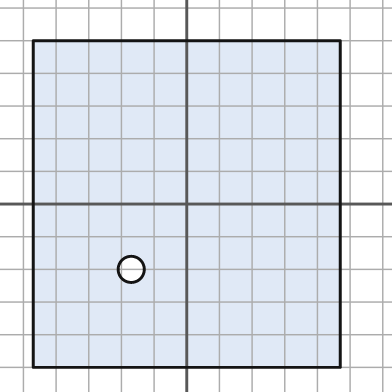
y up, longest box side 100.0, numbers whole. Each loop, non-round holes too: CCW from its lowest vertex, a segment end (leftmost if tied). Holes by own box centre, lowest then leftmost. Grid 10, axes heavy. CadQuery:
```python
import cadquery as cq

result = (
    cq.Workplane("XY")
    .moveTo(-47.0, -50.0)
    .lineTo(47.0, -50.0)
    .lineTo(47.0, 50.0)
    .lineTo(-47.0, 50.0)
    .close()
    .moveTo(-17.0, -20.0)
    .circle(4.0)
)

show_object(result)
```